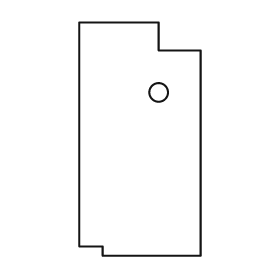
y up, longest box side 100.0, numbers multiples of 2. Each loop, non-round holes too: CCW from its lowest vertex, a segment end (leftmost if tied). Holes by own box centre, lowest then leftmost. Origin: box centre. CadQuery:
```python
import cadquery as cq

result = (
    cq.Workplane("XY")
    .moveTo(-16.0, -50.0)
    .lineTo(26.0, -50.0)
    .lineTo(26.0, 38.0)
    .lineTo(8.0, 38.0)
    .lineTo(8.0, 50.0)
    .lineTo(-26.0, 50.0)
    .lineTo(-26.0, -46.0)
    .lineTo(-16.0, -46.0)
    .close()
    .moveTo(8.0, 20.0)
    .circle(4.0)
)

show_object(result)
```